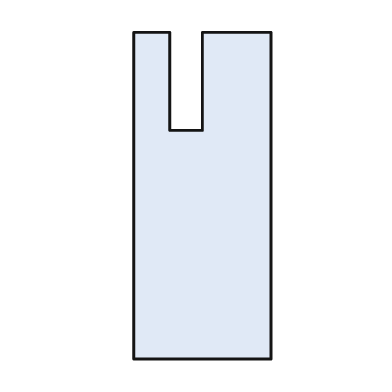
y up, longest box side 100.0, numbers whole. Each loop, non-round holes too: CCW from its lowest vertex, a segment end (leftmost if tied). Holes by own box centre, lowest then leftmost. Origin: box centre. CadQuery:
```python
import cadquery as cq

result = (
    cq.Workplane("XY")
    .moveTo(-21.0, -50.0)
    .lineTo(21.0, -50.0)
    .lineTo(21.0, 50.0)
    .lineTo(0.0, 50.0)
    .lineTo(0.0, 20.0)
    .lineTo(-10.0, 20.0)
    .lineTo(-10.0, 50.0)
    .lineTo(-21.0, 50.0)
    .close()
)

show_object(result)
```